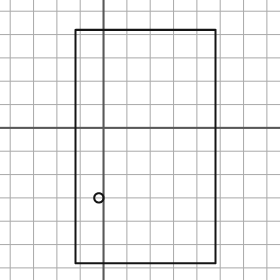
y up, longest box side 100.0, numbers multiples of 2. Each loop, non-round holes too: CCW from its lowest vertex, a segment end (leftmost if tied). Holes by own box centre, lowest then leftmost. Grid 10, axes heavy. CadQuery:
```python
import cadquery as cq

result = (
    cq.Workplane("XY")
    .moveTo(-12.0, -58.0)
    .lineTo(48.0, -58.0)
    .lineTo(48.0, 42.0)
    .lineTo(-12.0, 42.0)
    .close()
    .moveTo(-2.0, -30.0)
    .circle(2.0)
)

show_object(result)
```